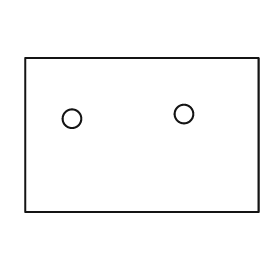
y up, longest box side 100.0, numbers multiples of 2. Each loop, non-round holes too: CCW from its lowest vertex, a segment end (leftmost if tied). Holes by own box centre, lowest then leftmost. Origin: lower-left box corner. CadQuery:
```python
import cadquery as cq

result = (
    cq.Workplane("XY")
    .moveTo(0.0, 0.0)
    .lineTo(100.0, 0.0)
    .lineTo(100.0, 66.0)
    .lineTo(0.0, 66.0)
    .close()
    .moveTo(20.0, 40.0)
    .circle(4.0)
    .moveTo(68.0, 42.0)
    .circle(4.0)
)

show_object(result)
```